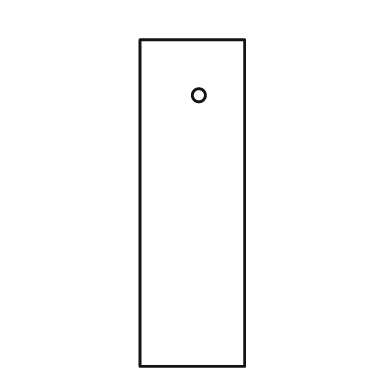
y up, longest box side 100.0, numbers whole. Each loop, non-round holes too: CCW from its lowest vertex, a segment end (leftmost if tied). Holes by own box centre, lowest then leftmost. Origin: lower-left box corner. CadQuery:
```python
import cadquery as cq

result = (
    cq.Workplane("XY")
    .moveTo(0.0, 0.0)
    .lineTo(32.0, 0.0)
    .lineTo(32.0, 100.0)
    .lineTo(0.0, 100.0)
    .close()
    .moveTo(18.0, 83.0)
    .circle(2.0)
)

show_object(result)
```